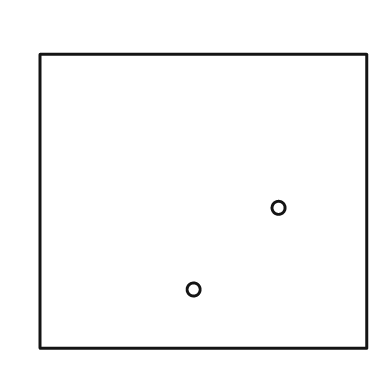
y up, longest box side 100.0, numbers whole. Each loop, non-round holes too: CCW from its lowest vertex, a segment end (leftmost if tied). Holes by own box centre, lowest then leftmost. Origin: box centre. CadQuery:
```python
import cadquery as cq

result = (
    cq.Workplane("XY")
    .moveTo(-50.0, -45.0)
    .lineTo(50.0, -45.0)
    .lineTo(50.0, 45.0)
    .lineTo(-50.0, 45.0)
    .close()
    .moveTo(-3.0, -27.0)
    .circle(2.0)
    .moveTo(23.0, -2.0)
    .circle(2.0)
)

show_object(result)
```